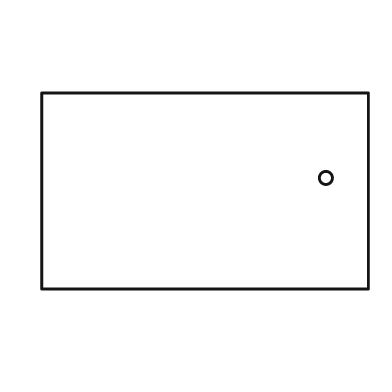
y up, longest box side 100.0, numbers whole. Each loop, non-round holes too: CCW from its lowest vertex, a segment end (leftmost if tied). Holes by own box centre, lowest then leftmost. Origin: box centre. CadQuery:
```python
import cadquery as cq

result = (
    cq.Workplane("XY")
    .moveTo(-50.0, -30.0)
    .lineTo(50.0, -30.0)
    .lineTo(50.0, 30.0)
    .lineTo(-50.0, 30.0)
    .close()
    .moveTo(37.0, 4.0)
    .circle(2.0)
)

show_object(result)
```